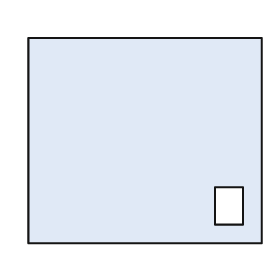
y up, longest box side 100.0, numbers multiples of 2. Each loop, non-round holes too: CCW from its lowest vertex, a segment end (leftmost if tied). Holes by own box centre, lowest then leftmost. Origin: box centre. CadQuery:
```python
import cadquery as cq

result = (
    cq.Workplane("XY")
    .moveTo(-50.0, -44.0)
    .lineTo(50.0, -44.0)
    .lineTo(50.0, 44.0)
    .lineTo(-50.0, 44.0)
    .close()
    .moveTo(30.0, -36.0)
    .lineTo(42.0, -36.0)
    .lineTo(42.0, -20.0)
    .lineTo(30.0, -20.0)
    .close()
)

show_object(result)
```